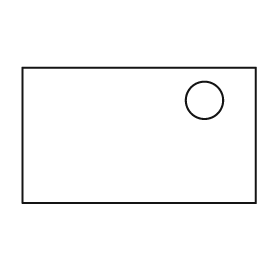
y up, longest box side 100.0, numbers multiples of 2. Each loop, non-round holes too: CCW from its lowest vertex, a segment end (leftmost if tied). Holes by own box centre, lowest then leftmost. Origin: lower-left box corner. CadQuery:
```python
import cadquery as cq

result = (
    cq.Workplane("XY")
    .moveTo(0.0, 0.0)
    .lineTo(100.0, 0.0)
    .lineTo(100.0, 58.0)
    .lineTo(0.0, 58.0)
    .close()
    .moveTo(78.0, 44.0)
    .circle(8.0)
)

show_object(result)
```